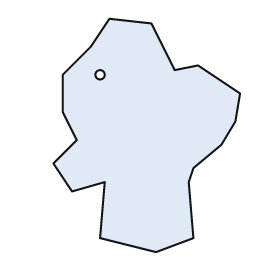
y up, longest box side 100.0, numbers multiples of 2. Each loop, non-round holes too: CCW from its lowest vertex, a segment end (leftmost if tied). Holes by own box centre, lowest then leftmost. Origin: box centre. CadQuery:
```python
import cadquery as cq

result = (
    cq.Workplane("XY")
    .moveTo(4.0, -50.0)
    .lineTo(20.0, -44.0)
    .lineTo(18.0, -20.0)
    .lineTo(20.0, -14.0)
    .lineTo(32.0, -4.0)
    .lineTo(38.0, 6.0)
    .lineTo(40.0, 18.0)
    .lineTo(22.0, 30.0)
    .lineTo(12.0, 28.0)
    .lineTo(2.0, 48.0)
    .lineTo(-16.0, 50.0)
    .lineTo(-24.0, 38.0)
    .lineTo(-36.0, 26.0)
    .lineTo(-36.0, 10.0)
    .lineTo(-30.0, -2.0)
    .lineTo(-40.0, -12.0)
    .lineTo(-32.0, -24.0)
    .lineTo(-18.0, -20.0)
    .lineTo(-20.0, -44.0)
    .close()
    .moveTo(-20.0, 26.0)
    .circle(2.0)
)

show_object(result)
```